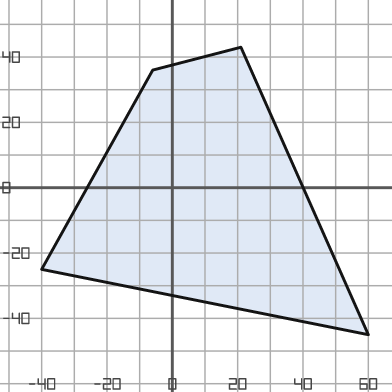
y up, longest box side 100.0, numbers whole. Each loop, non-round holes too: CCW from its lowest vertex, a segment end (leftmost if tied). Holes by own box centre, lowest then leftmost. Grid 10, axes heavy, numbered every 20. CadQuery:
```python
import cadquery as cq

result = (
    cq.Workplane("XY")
    .moveTo(60.0, -45.0)
    .lineTo(21.0, 43.0)
    .lineTo(-6.0, 36.0)
    .lineTo(-40.0, -25.0)
    .close()
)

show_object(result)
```